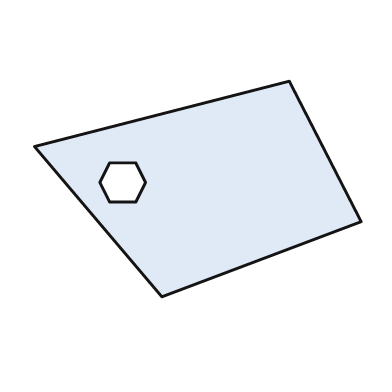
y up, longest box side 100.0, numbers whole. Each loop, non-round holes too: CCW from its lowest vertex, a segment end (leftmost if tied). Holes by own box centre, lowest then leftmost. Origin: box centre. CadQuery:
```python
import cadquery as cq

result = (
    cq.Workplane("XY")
    .moveTo(-11.0, -33.0)
    .lineTo(50.0, -10.0)
    .lineTo(28.0, 33.0)
    .lineTo(-50.0, 13.0)
    .close()
    .moveTo(-27.0, -4.0)
    .lineTo(-19.0, -4.0)
    .lineTo(-16.0, 2.0)
    .lineTo(-19.0, 8.0)
    .lineTo(-27.0, 8.0)
    .lineTo(-30.0, 2.0)
    .close()
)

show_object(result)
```